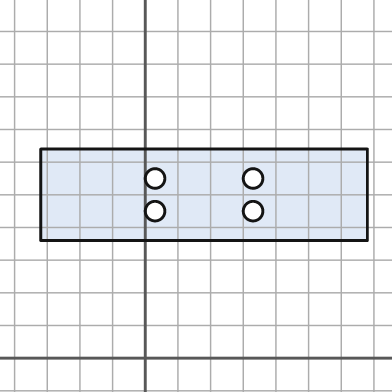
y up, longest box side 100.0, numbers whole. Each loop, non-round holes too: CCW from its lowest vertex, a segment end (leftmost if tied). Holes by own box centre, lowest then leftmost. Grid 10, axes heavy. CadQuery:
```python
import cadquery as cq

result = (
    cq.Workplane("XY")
    .moveTo(-32.0, 36.0)
    .lineTo(68.0, 36.0)
    .lineTo(68.0, 64.0)
    .lineTo(-32.0, 64.0)
    .close()
    .moveTo(3.0, 45.0)
    .circle(3.0)
    .moveTo(33.0, 45.0)
    .circle(3.0)
    .moveTo(3.0, 55.0)
    .circle(3.0)
    .moveTo(33.0, 55.0)
    .circle(3.0)
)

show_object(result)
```